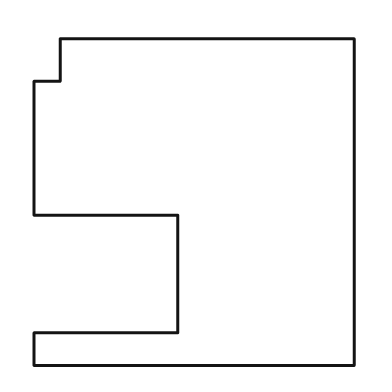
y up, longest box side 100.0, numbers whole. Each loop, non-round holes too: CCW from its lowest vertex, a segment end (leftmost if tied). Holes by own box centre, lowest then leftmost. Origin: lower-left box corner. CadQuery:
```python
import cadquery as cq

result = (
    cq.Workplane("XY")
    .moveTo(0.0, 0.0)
    .lineTo(98.0, 0.0)
    .lineTo(98.0, 100.0)
    .lineTo(8.0, 100.0)
    .lineTo(8.0, 87.0)
    .lineTo(0.0, 87.0)
    .lineTo(0.0, 46.0)
    .lineTo(44.0, 46.0)
    .lineTo(44.0, 10.0)
    .lineTo(0.0, 10.0)
    .close()
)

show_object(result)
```